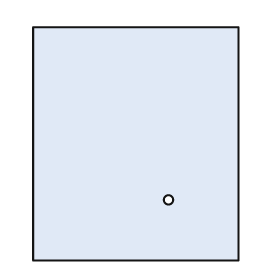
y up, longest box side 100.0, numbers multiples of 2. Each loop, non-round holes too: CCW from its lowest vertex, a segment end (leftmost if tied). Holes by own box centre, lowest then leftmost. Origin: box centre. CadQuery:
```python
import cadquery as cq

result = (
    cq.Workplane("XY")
    .moveTo(-44.0, -50.0)
    .lineTo(44.0, -50.0)
    .lineTo(44.0, 50.0)
    .lineTo(-44.0, 50.0)
    .close()
    .moveTo(14.0, -24.0)
    .circle(2.0)
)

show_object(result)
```